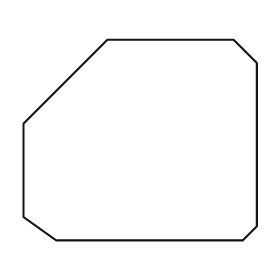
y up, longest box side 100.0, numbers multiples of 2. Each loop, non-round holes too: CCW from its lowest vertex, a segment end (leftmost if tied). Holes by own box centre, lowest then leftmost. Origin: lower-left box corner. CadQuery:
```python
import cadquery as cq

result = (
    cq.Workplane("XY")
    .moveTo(14.0, 0.0)
    .lineTo(94.0, 0.0)
    .lineTo(100.0, 6.0)
    .lineTo(100.0, 76.0)
    .lineTo(90.0, 86.0)
    .lineTo(36.0, 86.0)
    .lineTo(0.0, 50.0)
    .lineTo(0.0, 10.0)
    .close()
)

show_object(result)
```